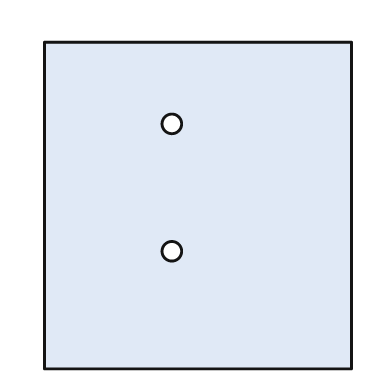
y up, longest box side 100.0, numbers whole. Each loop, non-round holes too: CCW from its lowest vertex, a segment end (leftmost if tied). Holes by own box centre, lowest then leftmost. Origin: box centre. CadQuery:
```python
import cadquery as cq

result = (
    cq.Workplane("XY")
    .moveTo(-47.0, -50.0)
    .lineTo(47.0, -50.0)
    .lineTo(47.0, 50.0)
    .lineTo(-47.0, 50.0)
    .close()
    .moveTo(-8.0, -14.0)
    .circle(3.0)
    .moveTo(-8.0, 25.0)
    .circle(3.0)
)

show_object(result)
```